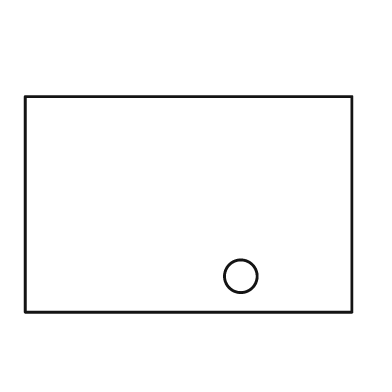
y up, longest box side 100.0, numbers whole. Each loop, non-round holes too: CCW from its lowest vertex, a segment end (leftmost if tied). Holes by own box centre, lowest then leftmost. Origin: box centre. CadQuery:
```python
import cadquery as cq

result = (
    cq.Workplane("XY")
    .moveTo(-50.0, -33.0)
    .lineTo(50.0, -33.0)
    .lineTo(50.0, 33.0)
    .lineTo(-50.0, 33.0)
    .close()
    .moveTo(16.0, -22.0)
    .circle(5.0)
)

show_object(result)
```